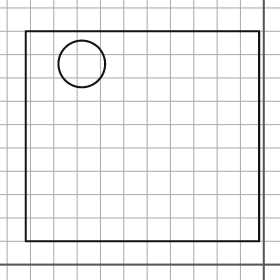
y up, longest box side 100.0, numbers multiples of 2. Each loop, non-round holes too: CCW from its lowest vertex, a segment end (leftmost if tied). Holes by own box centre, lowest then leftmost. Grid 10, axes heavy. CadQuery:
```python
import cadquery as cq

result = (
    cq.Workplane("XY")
    .moveTo(-102.0, 10.0)
    .lineTo(-2.0, 10.0)
    .lineTo(-2.0, 100.0)
    .lineTo(-102.0, 100.0)
    .close()
    .moveTo(-78.0, 86.0)
    .circle(10.0)
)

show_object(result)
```